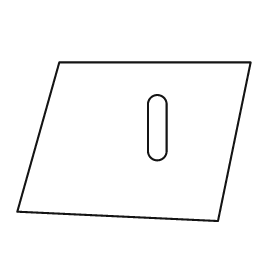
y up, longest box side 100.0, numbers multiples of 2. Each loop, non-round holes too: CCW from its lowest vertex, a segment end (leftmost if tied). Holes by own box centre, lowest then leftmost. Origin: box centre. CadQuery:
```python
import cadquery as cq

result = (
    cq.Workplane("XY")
    .moveTo(36.0, -34.0)
    .lineTo(50.0, 34.0)
    .lineTo(-32.0, 34.0)
    .lineTo(-50.0, -30.0)
    .close()
    .moveTo(6.0, -4.0)
    .threePointArc((10.0, -8.0), (14.0, -4.0))
    .lineTo(14.0, 16.0)
    .threePointArc((10.0, 20.0), (6.0, 16.0))
    .close()
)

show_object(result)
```